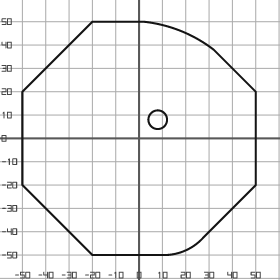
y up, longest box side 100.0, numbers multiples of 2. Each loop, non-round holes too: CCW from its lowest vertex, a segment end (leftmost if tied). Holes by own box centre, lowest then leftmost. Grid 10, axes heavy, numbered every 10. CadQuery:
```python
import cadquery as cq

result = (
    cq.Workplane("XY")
    .moveTo(-20.0, -50.0)
    .lineTo(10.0, -50.0)
    .threePointArc((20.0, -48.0), (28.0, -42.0))
    .lineTo(50.0, -20.0)
    .lineTo(50.0, 20.0)
    .lineTo(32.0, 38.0)
    .threePointArc((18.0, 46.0), (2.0, 50.0))
    .lineTo(-20.0, 50.0)
    .lineTo(-50.0, 20.0)
    .lineTo(-50.0, -20.0)
    .close()
    .moveTo(8.0, 8.0)
    .circle(4.0)
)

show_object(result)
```